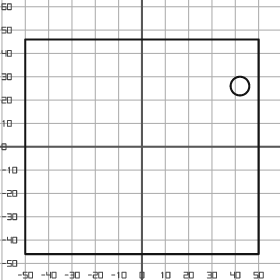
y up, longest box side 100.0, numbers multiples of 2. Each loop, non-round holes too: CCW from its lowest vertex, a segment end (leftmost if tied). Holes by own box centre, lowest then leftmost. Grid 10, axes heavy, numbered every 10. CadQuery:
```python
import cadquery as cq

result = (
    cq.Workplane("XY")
    .moveTo(-50.0, -46.0)
    .lineTo(50.0, -46.0)
    .lineTo(50.0, 46.0)
    .lineTo(-50.0, 46.0)
    .close()
    .moveTo(42.0, 26.0)
    .circle(4.0)
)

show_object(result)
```